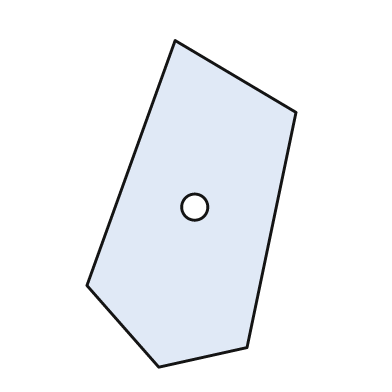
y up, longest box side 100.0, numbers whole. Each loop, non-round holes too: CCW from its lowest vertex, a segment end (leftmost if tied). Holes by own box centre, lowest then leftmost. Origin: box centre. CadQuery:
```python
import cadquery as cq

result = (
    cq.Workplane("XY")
    .moveTo(-10.0, -50.0)
    .lineTo(17.0, -44.0)
    .lineTo(32.0, 28.0)
    .lineTo(-5.0, 50.0)
    .lineTo(-32.0, -25.0)
    .close()
    .moveTo(1.0, -1.0)
    .circle(4.0)
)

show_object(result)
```